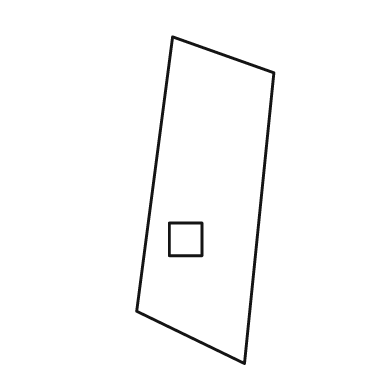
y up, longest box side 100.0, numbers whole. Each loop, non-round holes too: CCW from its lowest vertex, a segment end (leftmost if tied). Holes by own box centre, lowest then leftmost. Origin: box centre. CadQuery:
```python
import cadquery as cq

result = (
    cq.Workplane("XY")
    .moveTo(12.0, -50.0)
    .lineTo(21.0, 39.0)
    .lineTo(-10.0, 50.0)
    .lineTo(-21.0, -34.0)
    .close()
    .moveTo(-11.0, -17.0)
    .lineTo(-1.0, -17.0)
    .lineTo(-1.0, -7.0)
    .lineTo(-11.0, -7.0)
    .close()
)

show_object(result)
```